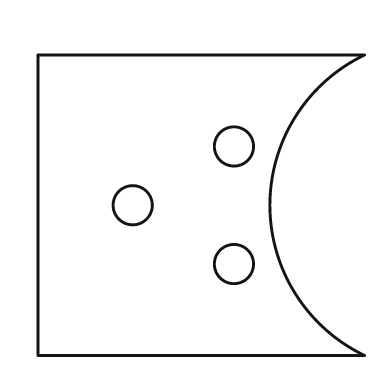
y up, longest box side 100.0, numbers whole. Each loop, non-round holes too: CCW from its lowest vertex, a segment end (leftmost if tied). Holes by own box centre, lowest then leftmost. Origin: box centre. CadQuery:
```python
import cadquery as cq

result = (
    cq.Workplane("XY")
    .moveTo(-50.0, -46.0)
    .lineTo(50.0, -46.0)
    .threePointArc((21.0, 0.0), (50.0, 46.0))
    .lineTo(-50.0, 46.0)
    .close()
    .moveTo(10.0, -18.0)
    .circle(6.0)
    .moveTo(-21.0, 0.0)
    .circle(6.0)
    .moveTo(10.0, 18.0)
    .circle(6.0)
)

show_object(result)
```